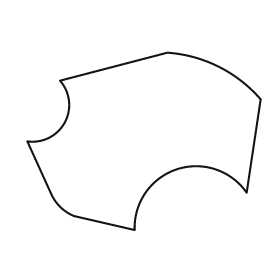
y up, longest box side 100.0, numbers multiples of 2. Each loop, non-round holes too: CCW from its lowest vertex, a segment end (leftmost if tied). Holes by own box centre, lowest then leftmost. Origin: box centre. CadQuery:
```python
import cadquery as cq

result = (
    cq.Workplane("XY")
    .moveTo(-4.0, -38.0)
    .threePointArc((14.0, -12.0), (44.0, -22.0))
    .lineTo(50.0, 18.0)
    .threePointArc((32.0, 32.0), (10.0, 38.0))
    .lineTo(-36.0, 26.0)
    .threePointArc((-34.0, 8.0), (-50.0, 0.0))
    .lineTo(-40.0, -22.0)
    .threePointArc((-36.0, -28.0), (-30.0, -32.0))
    .close()
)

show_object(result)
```